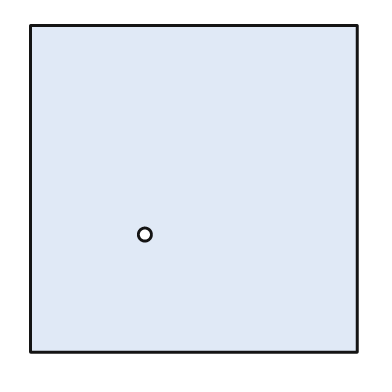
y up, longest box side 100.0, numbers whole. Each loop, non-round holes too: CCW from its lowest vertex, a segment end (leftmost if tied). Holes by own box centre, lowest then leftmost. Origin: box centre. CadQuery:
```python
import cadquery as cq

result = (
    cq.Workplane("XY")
    .moveTo(-50.0, -50.0)
    .lineTo(50.0, -50.0)
    .lineTo(50.0, 50.0)
    .lineTo(-50.0, 50.0)
    .close()
    .moveTo(-15.0, -14.0)
    .circle(2.0)
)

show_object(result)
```